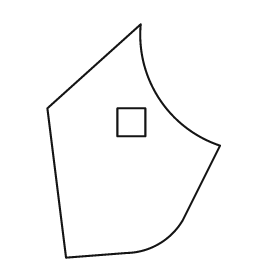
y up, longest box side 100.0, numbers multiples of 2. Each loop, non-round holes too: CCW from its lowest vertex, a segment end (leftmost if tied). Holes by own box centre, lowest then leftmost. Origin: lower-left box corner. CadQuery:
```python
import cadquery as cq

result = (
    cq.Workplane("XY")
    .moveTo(8.0, 0.0)
    .lineTo(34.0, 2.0)
    .threePointArc((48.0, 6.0), (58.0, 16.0))
    .lineTo(74.0, 48.0)
    .threePointArc((48.0, 68.0), (40.0, 100.0))
    .lineTo(0.0, 64.0)
    .close()
    .moveTo(30.0, 52.0)
    .lineTo(42.0, 52.0)
    .lineTo(42.0, 64.0)
    .lineTo(30.0, 64.0)
    .close()
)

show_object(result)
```